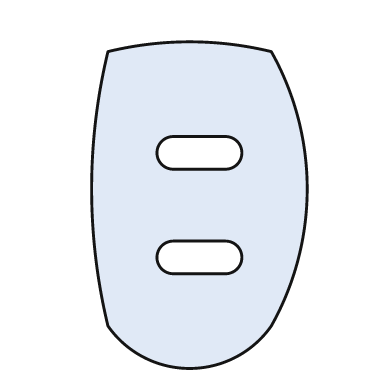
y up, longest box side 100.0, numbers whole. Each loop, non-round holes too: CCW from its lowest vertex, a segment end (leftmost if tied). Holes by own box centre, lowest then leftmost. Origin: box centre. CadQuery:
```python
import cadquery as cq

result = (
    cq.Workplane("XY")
    .moveTo(-28.0, -37.0)
    .threePointArc((-3.0, -50.0), (22.0, -37.0))
    .threePointArc((33.0, 5.0), (22.0, 47.0))
    .threePointArc((-3.0, 50.0), (-28.0, 47.0))
    .threePointArc((-33.0, 5.0), (-28.0, -37.0))
    .close()
    .moveTo(-8.0, -21.0)
    .lineTo(8.0, -21.0)
    .threePointArc((13.0, -16.0), (8.0, -11.0))
    .lineTo(-8.0, -11.0)
    .threePointArc((-13.0, -16.0), (-8.0, -21.0))
    .close()
    .moveTo(-8.0, 11.0)
    .lineTo(8.0, 11.0)
    .threePointArc((13.0, 16.0), (8.0, 21.0))
    .lineTo(-8.0, 21.0)
    .threePointArc((-13.0, 16.0), (-8.0, 11.0))
    .close()
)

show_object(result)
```